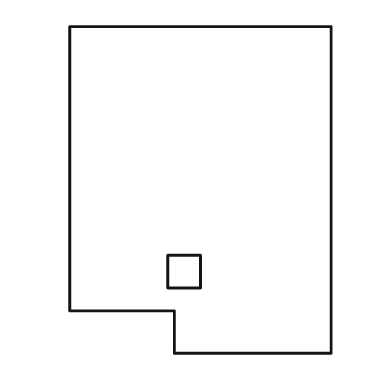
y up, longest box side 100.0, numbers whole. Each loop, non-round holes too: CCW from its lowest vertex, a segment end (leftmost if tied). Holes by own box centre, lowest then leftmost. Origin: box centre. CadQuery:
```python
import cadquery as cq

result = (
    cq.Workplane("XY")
    .moveTo(-8.0, -50.0)
    .lineTo(40.0, -50.0)
    .lineTo(40.0, 50.0)
    .lineTo(-40.0, 50.0)
    .lineTo(-40.0, -37.0)
    .lineTo(-8.0, -37.0)
    .close()
    .moveTo(-10.0, -30.0)
    .lineTo(0.0, -30.0)
    .lineTo(0.0, -20.0)
    .lineTo(-10.0, -20.0)
    .close()
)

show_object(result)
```